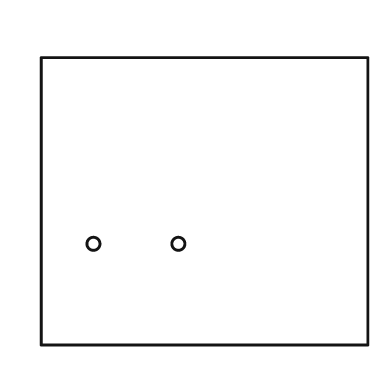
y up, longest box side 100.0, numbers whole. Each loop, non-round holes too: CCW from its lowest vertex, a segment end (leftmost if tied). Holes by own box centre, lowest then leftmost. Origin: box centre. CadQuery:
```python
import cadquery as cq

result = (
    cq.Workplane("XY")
    .moveTo(-50.0, -44.0)
    .lineTo(50.0, -44.0)
    .lineTo(50.0, 44.0)
    .lineTo(-50.0, 44.0)
    .close()
    .moveTo(-34.0, -13.0)
    .circle(2.0)
    .moveTo(-8.0, -13.0)
    .circle(2.0)
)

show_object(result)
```